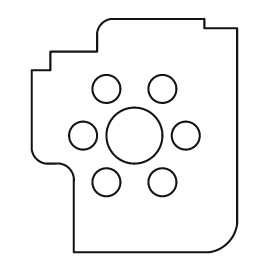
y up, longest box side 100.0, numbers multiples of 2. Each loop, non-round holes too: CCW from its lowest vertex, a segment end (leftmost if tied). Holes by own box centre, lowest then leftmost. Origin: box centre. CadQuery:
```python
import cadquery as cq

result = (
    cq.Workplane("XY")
    .moveTo(-26.0, -50.0)
    .lineTo(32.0, -50.0)
    .threePointArc((40.0, -46.0), (44.0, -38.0))
    .lineTo(44.0, 46.0)
    .lineTo(30.0, 46.0)
    .lineTo(30.0, 50.0)
    .lineTo(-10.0, 50.0)
    .threePointArc((-14.0, 48.0), (-16.0, 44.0))
    .lineTo(-16.0, 36.0)
    .lineTo(-36.0, 36.0)
    .lineTo(-36.0, 28.0)
    .lineTo(-44.0, 28.0)
    .lineTo(-44.0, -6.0)
    .threePointArc((-42.0, -10.0), (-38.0, -12.0))
    .lineTo(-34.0, -12.0)
    .threePointArc((-28.0, -14.0), (-26.0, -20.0))
    .close()
    .moveTo(-12.0, -20.0)
    .circle(6.0)
    .moveTo(12.0, -20.0)
    .circle(6.0)
    .moveTo(-22.0, 0.0)
    .circle(6.0)
    .moveTo(0.0, 0.0)
    .circle(12.0)
    .moveTo(22.0, 0.0)
    .circle(6.0)
    .moveTo(-12.0, 20.0)
    .circle(6.0)
    .moveTo(12.0, 20.0)
    .circle(6.0)
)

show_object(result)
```